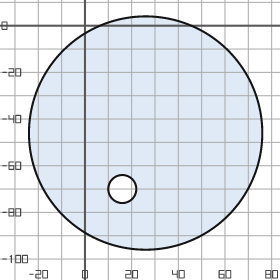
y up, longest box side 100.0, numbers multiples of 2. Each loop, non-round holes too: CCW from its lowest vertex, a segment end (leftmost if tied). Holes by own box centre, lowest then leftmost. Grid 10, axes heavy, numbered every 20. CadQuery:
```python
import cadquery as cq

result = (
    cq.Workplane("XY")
    .moveTo(26.0, -46.0)
    .circle(50.0)
    .moveTo(16.0, -70.0)
    .circle(6.0)
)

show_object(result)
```